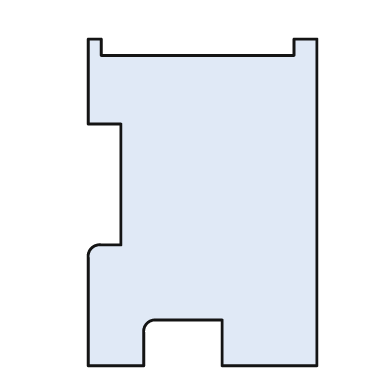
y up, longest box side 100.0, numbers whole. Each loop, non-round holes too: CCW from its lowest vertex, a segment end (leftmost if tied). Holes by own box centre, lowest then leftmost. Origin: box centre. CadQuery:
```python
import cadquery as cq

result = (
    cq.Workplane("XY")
    .moveTo(-35.0, -50.0)
    .lineTo(-18.0, -50.0)
    .lineTo(-18.0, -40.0)
    .threePointArc((-17.0, -37.0), (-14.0, -36.0))
    .lineTo(6.0, -36.0)
    .lineTo(6.0, -50.0)
    .lineTo(35.0, -50.0)
    .lineTo(35.0, 50.0)
    .lineTo(28.0, 50.0)
    .lineTo(28.0, 45.0)
    .lineTo(-31.0, 45.0)
    .lineTo(-31.0, 50.0)
    .lineTo(-35.0, 50.0)
    .lineTo(-35.0, 24.0)
    .lineTo(-25.0, 24.0)
    .lineTo(-25.0, -13.0)
    .lineTo(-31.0, -13.0)
    .threePointArc((-34.0, -14.0), (-35.0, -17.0))
    .close()
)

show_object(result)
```